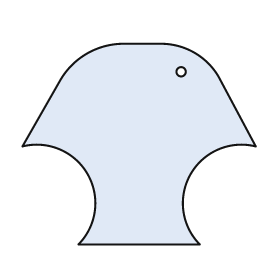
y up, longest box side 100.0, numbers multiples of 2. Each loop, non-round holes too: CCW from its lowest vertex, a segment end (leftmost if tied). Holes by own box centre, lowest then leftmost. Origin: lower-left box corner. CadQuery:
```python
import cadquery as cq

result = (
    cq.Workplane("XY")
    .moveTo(24.0, 0.0)
    .lineTo(76.0, 0.0)
    .threePointArc((72.0, 30.0), (100.0, 42.0))
    .lineTo(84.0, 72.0)
    .threePointArc((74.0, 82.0), (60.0, 86.0))
    .lineTo(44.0, 86.0)
    .threePointArc((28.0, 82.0), (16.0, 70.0))
    .lineTo(0.0, 42.0)
    .threePointArc((28.0, 30.0), (24.0, 0.0))
    .close()
    .moveTo(68.0, 74.0)
    .circle(2.0)
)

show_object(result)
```